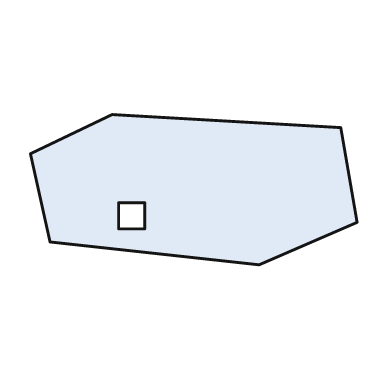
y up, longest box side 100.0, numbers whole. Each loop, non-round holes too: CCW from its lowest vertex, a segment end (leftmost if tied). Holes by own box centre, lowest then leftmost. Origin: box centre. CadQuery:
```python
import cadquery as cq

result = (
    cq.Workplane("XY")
    .moveTo(20.0, -23.0)
    .lineTo(50.0, -10.0)
    .lineTo(45.0, 19.0)
    .lineTo(-25.0, 23.0)
    .lineTo(-50.0, 11.0)
    .lineTo(-44.0, -16.0)
    .close()
    .moveTo(-23.0, -12.0)
    .lineTo(-15.0, -12.0)
    .lineTo(-15.0, -4.0)
    .lineTo(-23.0, -4.0)
    .close()
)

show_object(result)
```